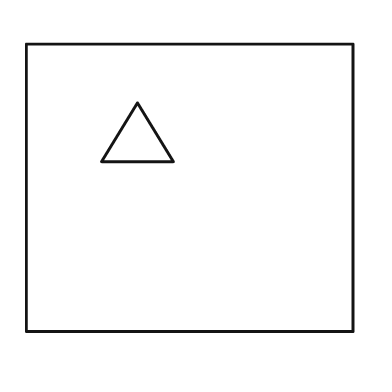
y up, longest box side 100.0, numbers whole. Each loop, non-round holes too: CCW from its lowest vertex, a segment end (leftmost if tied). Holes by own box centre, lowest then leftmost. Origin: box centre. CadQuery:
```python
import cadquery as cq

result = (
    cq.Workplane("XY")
    .moveTo(-50.0, -44.0)
    .lineTo(50.0, -44.0)
    .lineTo(50.0, 44.0)
    .lineTo(-50.0, 44.0)
    .close()
    .moveTo(-27.0, 8.0)
    .lineTo(-5.0, 8.0)
    .lineTo(-16.0, 26.0)
    .close()
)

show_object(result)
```